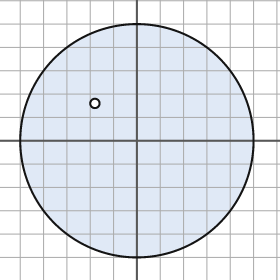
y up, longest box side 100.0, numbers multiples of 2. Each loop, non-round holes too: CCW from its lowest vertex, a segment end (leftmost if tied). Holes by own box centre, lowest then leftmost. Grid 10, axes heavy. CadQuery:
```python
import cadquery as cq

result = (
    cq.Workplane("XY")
    .moveTo(0.0, 0.0)
    .circle(50.0)
    .moveTo(-18.0, 16.0)
    .circle(2.0)
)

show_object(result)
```